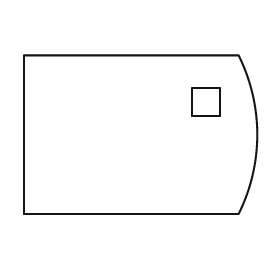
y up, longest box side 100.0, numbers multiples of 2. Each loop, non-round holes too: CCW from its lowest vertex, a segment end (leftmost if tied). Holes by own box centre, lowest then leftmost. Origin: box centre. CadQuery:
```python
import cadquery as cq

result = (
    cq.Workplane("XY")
    .moveTo(-50.0, -34.0)
    .lineTo(42.0, -34.0)
    .threePointArc((50.0, 0.0), (42.0, 34.0))
    .lineTo(-50.0, 34.0)
    .close()
    .moveTo(22.0, 8.0)
    .lineTo(34.0, 8.0)
    .lineTo(34.0, 20.0)
    .lineTo(22.0, 20.0)
    .close()
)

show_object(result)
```